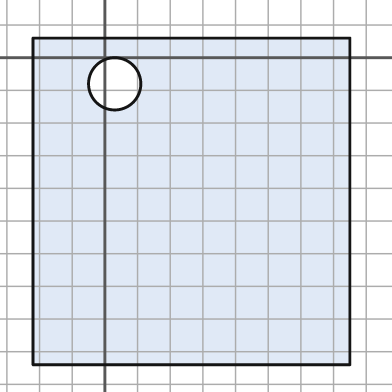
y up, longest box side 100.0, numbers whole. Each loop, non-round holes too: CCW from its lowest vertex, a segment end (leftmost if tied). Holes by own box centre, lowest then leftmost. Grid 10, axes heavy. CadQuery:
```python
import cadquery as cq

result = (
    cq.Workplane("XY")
    .moveTo(-22.0, -94.0)
    .lineTo(75.0, -94.0)
    .lineTo(75.0, 6.0)
    .lineTo(-22.0, 6.0)
    .close()
    .moveTo(3.0, -8.0)
    .circle(8.0)
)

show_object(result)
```